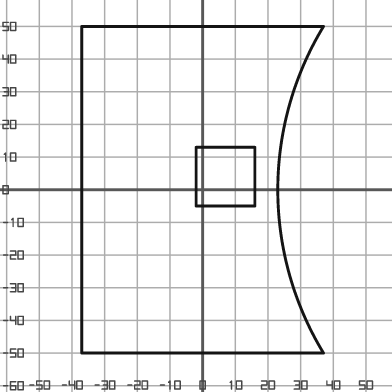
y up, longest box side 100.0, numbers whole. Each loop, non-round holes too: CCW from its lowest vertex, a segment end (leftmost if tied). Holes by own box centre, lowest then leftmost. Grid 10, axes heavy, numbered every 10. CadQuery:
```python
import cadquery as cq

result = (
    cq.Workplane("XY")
    .moveTo(-37.0, -50.0)
    .lineTo(37.0, -50.0)
    .threePointArc((23.0, 0.0), (37.0, 50.0))
    .lineTo(-37.0, 50.0)
    .close()
    .moveTo(-2.0, -5.0)
    .lineTo(16.0, -5.0)
    .lineTo(16.0, 13.0)
    .lineTo(-2.0, 13.0)
    .close()
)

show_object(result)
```